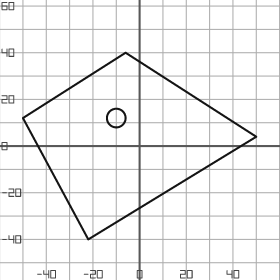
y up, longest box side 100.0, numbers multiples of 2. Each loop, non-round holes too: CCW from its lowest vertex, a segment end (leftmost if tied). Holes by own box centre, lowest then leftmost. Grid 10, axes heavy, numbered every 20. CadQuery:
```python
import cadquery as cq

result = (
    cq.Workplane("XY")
    .moveTo(-22.0, -40.0)
    .lineTo(50.0, 4.0)
    .lineTo(-6.0, 40.0)
    .lineTo(-50.0, 12.0)
    .close()
    .moveTo(-10.0, 12.0)
    .circle(4.0)
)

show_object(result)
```